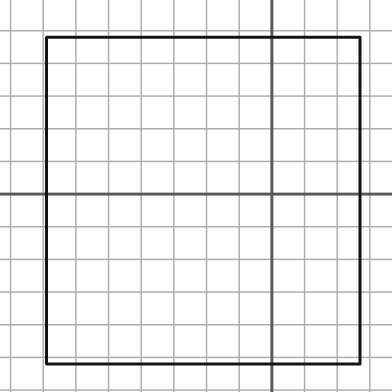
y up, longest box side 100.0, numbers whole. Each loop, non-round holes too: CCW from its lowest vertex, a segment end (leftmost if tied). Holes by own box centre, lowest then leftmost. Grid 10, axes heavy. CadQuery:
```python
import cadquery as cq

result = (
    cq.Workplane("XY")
    .moveTo(-69.0, -52.0)
    .lineTo(27.0, -52.0)
    .lineTo(27.0, 48.0)
    .lineTo(-69.0, 48.0)
    .close()
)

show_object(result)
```